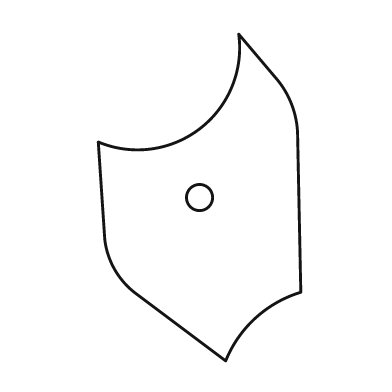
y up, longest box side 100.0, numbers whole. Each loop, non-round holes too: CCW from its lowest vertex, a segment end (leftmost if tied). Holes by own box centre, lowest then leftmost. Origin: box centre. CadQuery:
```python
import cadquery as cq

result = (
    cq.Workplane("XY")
    .moveTo(8.0, -50.0)
    .threePointArc((17.0, -37.0), (31.0, -29.0))
    .lineTo(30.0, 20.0)
    .threePointArc((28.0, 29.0), (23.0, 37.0))
    .lineTo(12.0, 50.0)
    .threePointArc((0.0, 21.0), (-31.0, 17.0))
    .lineTo(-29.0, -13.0)
    .threePointArc((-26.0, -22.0), (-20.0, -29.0))
    .close()
    .moveTo(0.0, 0.0)
    .circle(4.0)
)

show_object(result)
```